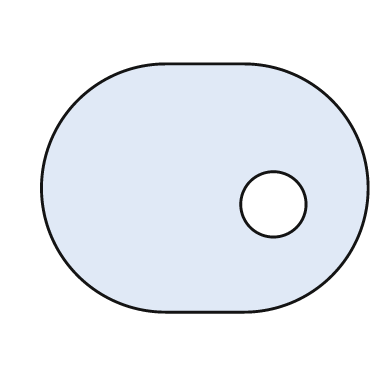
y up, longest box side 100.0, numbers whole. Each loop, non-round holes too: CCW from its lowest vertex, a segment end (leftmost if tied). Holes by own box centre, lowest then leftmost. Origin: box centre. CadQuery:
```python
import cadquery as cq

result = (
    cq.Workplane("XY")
    .moveTo(-12.0, -38.0)
    .lineTo(12.0, -38.0)
    .threePointArc((50.0, 0.0), (12.0, 38.0))
    .lineTo(-12.0, 38.0)
    .threePointArc((-50.0, 0.0), (-12.0, -38.0))
    .close()
    .moveTo(21.0, -5.0)
    .circle(10.0)
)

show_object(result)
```